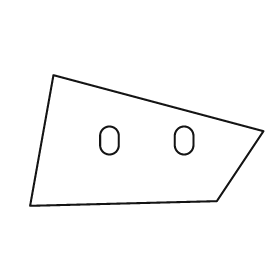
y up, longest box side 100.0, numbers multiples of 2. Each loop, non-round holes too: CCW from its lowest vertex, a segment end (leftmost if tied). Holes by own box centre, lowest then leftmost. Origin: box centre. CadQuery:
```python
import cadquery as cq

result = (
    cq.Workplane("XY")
    .moveTo(-50.0, -28.0)
    .lineTo(30.0, -26.0)
    .lineTo(50.0, 4.0)
    .lineTo(-40.0, 28.0)
    .close()
    .moveTo(-20.0, -2.0)
    .threePointArc((-16.0, -6.0), (-12.0, -2.0))
    .lineTo(-12.0, 2.0)
    .threePointArc((-16.0, 6.0), (-20.0, 2.0))
    .close()
    .moveTo(12.0, -2.0)
    .threePointArc((16.0, -6.0), (20.0, -2.0))
    .lineTo(20.0, 2.0)
    .threePointArc((16.0, 6.0), (12.0, 2.0))
    .close()
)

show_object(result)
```